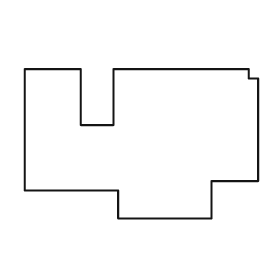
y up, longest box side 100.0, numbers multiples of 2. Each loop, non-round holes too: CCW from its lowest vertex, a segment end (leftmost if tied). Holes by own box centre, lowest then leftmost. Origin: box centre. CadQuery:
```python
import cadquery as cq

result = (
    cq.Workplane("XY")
    .moveTo(-10.0, -32.0)
    .lineTo(30.0, -32.0)
    .lineTo(30.0, -16.0)
    .lineTo(50.0, -16.0)
    .lineTo(50.0, 28.0)
    .lineTo(46.0, 28.0)
    .lineTo(46.0, 32.0)
    .lineTo(-12.0, 32.0)
    .lineTo(-12.0, 8.0)
    .lineTo(-26.0, 8.0)
    .lineTo(-26.0, 32.0)
    .lineTo(-50.0, 32.0)
    .lineTo(-50.0, -20.0)
    .lineTo(-10.0, -20.0)
    .close()
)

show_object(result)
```